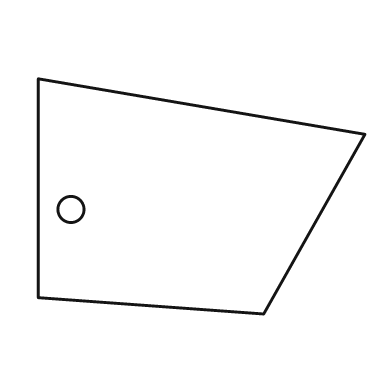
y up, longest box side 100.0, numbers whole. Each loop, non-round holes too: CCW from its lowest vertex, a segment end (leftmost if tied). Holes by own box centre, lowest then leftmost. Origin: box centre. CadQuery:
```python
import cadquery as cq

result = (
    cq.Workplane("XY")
    .moveTo(19.0, -36.0)
    .lineTo(50.0, 19.0)
    .lineTo(-50.0, 36.0)
    .lineTo(-50.0, -31.0)
    .close()
    .moveTo(-40.0, -4.0)
    .circle(4.0)
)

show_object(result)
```